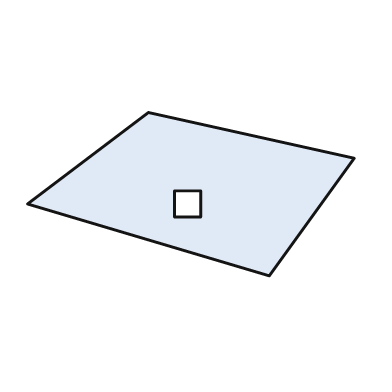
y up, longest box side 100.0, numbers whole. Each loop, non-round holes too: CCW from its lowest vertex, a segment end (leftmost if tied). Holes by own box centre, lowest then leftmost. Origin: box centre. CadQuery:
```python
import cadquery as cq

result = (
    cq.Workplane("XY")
    .moveTo(24.0, -25.0)
    .lineTo(50.0, 11.0)
    .lineTo(-13.0, 25.0)
    .lineTo(-50.0, -3.0)
    .close()
    .moveTo(-5.0, -7.0)
    .lineTo(3.0, -7.0)
    .lineTo(3.0, 1.0)
    .lineTo(-5.0, 1.0)
    .close()
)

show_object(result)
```